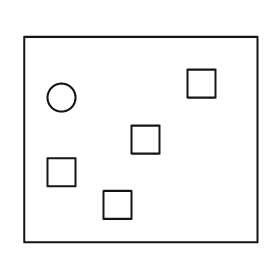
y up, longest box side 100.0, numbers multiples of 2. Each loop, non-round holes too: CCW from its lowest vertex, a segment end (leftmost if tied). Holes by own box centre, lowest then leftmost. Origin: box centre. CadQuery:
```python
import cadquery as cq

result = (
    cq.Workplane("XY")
    .moveTo(-50.0, -44.0)
    .lineTo(50.0, -44.0)
    .lineTo(50.0, 44.0)
    .lineTo(-50.0, 44.0)
    .close()
    .moveTo(-16.0, -34.0)
    .lineTo(-4.0, -34.0)
    .lineTo(-4.0, -22.0)
    .lineTo(-16.0, -22.0)
    .close()
    .moveTo(-40.0, -20.0)
    .lineTo(-28.0, -20.0)
    .lineTo(-28.0, -8.0)
    .lineTo(-40.0, -8.0)
    .close()
    .moveTo(-4.0, -6.0)
    .lineTo(8.0, -6.0)
    .lineTo(8.0, 6.0)
    .lineTo(-4.0, 6.0)
    .close()
    .moveTo(-34.0, 18.0)
    .circle(6.0)
    .moveTo(20.0, 18.0)
    .lineTo(32.0, 18.0)
    .lineTo(32.0, 30.0)
    .lineTo(20.0, 30.0)
    .close()
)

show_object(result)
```